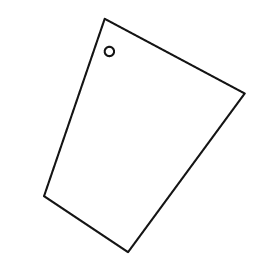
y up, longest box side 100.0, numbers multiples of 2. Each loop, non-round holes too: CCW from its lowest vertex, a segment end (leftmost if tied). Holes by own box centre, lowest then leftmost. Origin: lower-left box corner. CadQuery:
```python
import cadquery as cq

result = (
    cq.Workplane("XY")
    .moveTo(36.0, 0.0)
    .lineTo(86.0, 68.0)
    .lineTo(26.0, 100.0)
    .lineTo(0.0, 24.0)
    .close()
    .moveTo(28.0, 86.0)
    .circle(2.0)
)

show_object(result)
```